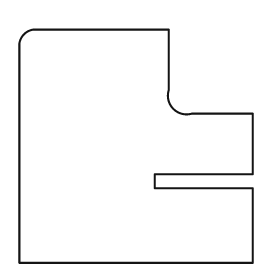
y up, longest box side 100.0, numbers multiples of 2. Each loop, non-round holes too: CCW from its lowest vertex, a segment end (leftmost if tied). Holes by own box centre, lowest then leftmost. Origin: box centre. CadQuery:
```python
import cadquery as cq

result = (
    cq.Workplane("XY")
    .moveTo(-50.0, -50.0)
    .lineTo(50.0, -50.0)
    .lineTo(50.0, -18.0)
    .lineTo(8.0, -18.0)
    .lineTo(8.0, -12.0)
    .lineTo(50.0, -12.0)
    .lineTo(50.0, 14.0)
    .lineTo(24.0, 14.0)
    .threePointArc((16.0, 16.0), (14.0, 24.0))
    .lineTo(14.0, 50.0)
    .lineTo(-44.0, 50.0)
    .threePointArc((-48.0, 48.0), (-50.0, 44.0))
    .close()
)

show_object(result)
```